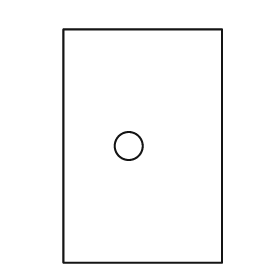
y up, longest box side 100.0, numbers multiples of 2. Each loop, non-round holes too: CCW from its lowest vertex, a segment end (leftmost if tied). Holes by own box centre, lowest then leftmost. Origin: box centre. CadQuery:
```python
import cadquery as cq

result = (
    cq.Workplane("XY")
    .moveTo(-34.0, -50.0)
    .lineTo(34.0, -50.0)
    .lineTo(34.0, 50.0)
    .lineTo(-34.0, 50.0)
    .close()
    .moveTo(-6.0, 0.0)
    .circle(6.0)
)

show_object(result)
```